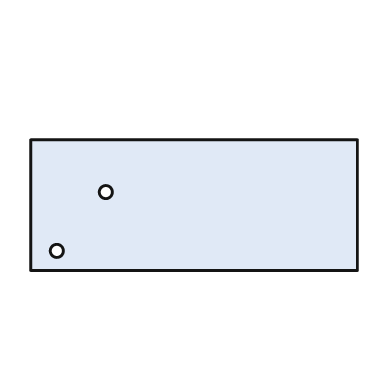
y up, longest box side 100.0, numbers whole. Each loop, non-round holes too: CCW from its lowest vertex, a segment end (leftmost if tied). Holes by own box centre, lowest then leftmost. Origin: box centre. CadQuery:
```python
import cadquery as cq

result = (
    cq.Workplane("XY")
    .moveTo(-50.0, -20.0)
    .lineTo(50.0, -20.0)
    .lineTo(50.0, 20.0)
    .lineTo(-50.0, 20.0)
    .close()
    .moveTo(-42.0, -14.0)
    .circle(2.0)
    .moveTo(-27.0, 4.0)
    .circle(2.0)
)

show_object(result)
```